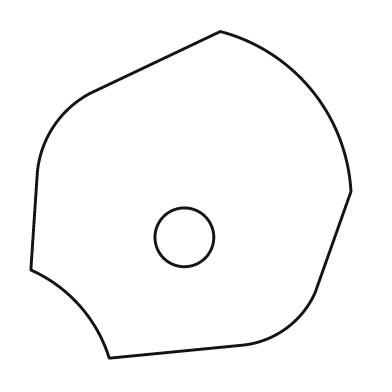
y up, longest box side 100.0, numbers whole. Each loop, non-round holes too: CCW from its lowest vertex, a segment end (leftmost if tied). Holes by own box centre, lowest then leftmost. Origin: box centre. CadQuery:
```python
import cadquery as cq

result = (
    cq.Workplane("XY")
    .moveTo(-25.0, -50.0)
    .lineTo(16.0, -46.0)
    .threePointArc((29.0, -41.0), (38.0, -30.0))
    .lineTo(49.0, 1.0)
    .threePointArc((37.0, 32.0), (9.0, 50.0))
    .lineTo(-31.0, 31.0)
    .threePointArc((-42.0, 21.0), (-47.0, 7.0))
    .lineTo(-49.0, -23.0)
    .threePointArc((-34.0, -34.0), (-25.0, -50.0))
    .close()
    .moveTo(-2.0, -13.0)
    .circle(9.0)
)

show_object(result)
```